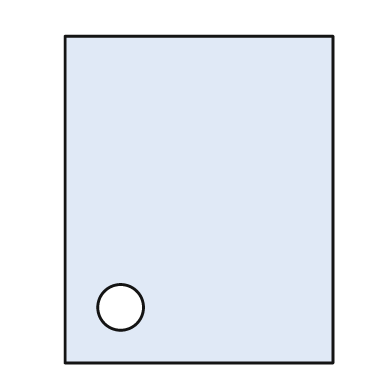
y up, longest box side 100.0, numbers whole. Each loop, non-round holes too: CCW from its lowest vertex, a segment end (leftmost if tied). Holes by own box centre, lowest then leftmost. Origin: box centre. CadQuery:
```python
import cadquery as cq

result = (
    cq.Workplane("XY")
    .moveTo(-41.0, -50.0)
    .lineTo(41.0, -50.0)
    .lineTo(41.0, 50.0)
    .lineTo(-41.0, 50.0)
    .close()
    .moveTo(-24.0, -33.0)
    .circle(7.0)
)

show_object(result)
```